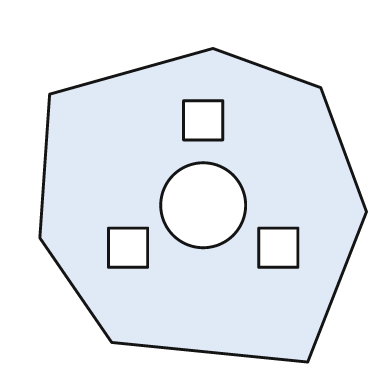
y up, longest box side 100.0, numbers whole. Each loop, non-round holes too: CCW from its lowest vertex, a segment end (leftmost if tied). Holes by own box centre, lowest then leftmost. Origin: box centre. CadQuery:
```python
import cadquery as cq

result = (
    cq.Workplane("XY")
    .moveTo(32.0, -48.0)
    .lineTo(50.0, -2.0)
    .lineTo(36.0, 36.0)
    .lineTo(3.0, 48.0)
    .lineTo(-47.0, 34.0)
    .lineTo(-50.0, -10.0)
    .lineTo(-28.0, -42.0)
    .close()
    .moveTo(-29.0, -19.0)
    .lineTo(-17.0, -19.0)
    .lineTo(-17.0, -7.0)
    .lineTo(-29.0, -7.0)
    .close()
    .moveTo(17.0, -19.0)
    .lineTo(29.0, -19.0)
    .lineTo(29.0, -7.0)
    .lineTo(17.0, -7.0)
    .close()
    .moveTo(0.0, 0.0)
    .circle(13.0)
    .moveTo(-6.0, 20.0)
    .lineTo(6.0, 20.0)
    .lineTo(6.0, 32.0)
    .lineTo(-6.0, 32.0)
    .close()
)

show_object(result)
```